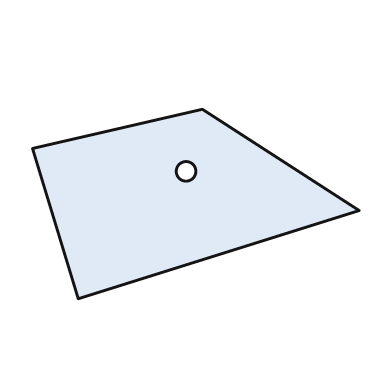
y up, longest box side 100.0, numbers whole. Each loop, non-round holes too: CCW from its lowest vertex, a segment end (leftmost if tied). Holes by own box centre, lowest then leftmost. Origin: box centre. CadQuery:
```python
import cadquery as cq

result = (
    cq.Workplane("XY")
    .moveTo(-36.0, -29.0)
    .lineTo(50.0, -2.0)
    .lineTo(2.0, 29.0)
    .lineTo(-50.0, 17.0)
    .close()
    .moveTo(-3.0, 10.0)
    .circle(3.0)
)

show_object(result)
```